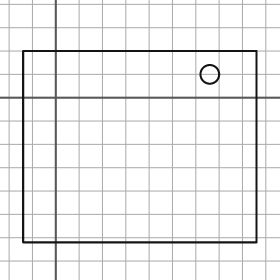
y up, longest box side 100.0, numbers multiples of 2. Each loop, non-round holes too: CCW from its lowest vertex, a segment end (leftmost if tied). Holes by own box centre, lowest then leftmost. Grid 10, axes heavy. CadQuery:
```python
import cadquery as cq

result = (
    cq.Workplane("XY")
    .moveTo(-14.0, -62.0)
    .lineTo(86.0, -62.0)
    .lineTo(86.0, 20.0)
    .lineTo(-14.0, 20.0)
    .close()
    .moveTo(66.0, 10.0)
    .circle(4.0)
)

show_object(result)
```